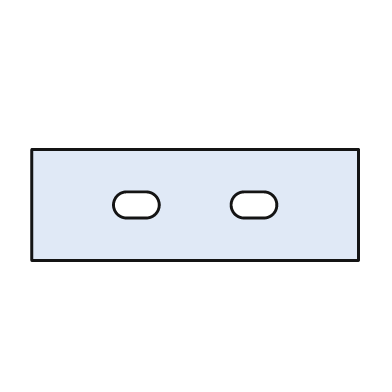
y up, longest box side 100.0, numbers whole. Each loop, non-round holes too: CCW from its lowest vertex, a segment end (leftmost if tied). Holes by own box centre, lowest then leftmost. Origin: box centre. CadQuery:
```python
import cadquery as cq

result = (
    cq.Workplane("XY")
    .moveTo(-50.0, -17.0)
    .lineTo(50.0, -17.0)
    .lineTo(50.0, 17.0)
    .lineTo(-50.0, 17.0)
    .close()
    .moveTo(-21.0, -4.0)
    .lineTo(-15.0, -4.0)
    .threePointArc((-11.0, 0.0), (-15.0, 4.0))
    .lineTo(-21.0, 4.0)
    .threePointArc((-25.0, 0.0), (-21.0, -4.0))
    .close()
    .moveTo(15.0, -4.0)
    .lineTo(21.0, -4.0)
    .threePointArc((25.0, 0.0), (21.0, 4.0))
    .lineTo(15.0, 4.0)
    .threePointArc((11.0, 0.0), (15.0, -4.0))
    .close()
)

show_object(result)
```